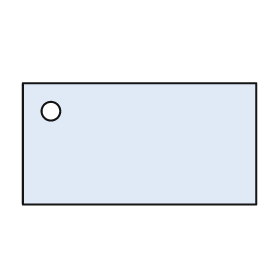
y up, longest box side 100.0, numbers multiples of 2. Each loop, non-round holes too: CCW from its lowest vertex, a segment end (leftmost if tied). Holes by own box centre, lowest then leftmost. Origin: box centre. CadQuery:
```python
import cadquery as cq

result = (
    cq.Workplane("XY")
    .moveTo(-50.0, -26.0)
    .lineTo(50.0, -26.0)
    .lineTo(50.0, 26.0)
    .lineTo(-50.0, 26.0)
    .close()
    .moveTo(-38.0, 14.0)
    .circle(4.0)
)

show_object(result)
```